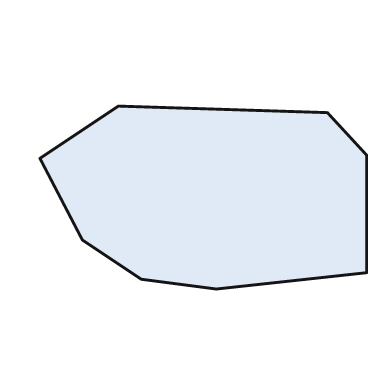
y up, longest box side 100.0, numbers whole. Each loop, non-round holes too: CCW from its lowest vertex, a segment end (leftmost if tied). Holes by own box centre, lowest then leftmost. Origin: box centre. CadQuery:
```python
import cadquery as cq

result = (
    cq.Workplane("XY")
    .moveTo(4.0, -28.0)
    .lineTo(50.0, -23.0)
    .lineTo(50.0, 13.0)
    .lineTo(38.0, 26.0)
    .lineTo(-26.0, 28.0)
    .lineTo(-50.0, 12.0)
    .lineTo(-37.0, -13.0)
    .lineTo(-19.0, -25.0)
    .close()
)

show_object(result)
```